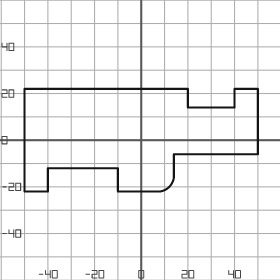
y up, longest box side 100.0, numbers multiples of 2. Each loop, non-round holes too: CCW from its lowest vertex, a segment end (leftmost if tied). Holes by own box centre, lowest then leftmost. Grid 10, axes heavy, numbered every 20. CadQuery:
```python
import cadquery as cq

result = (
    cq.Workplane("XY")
    .moveTo(-50.0, -22.0)
    .lineTo(-40.0, -22.0)
    .lineTo(-40.0, -12.0)
    .lineTo(-10.0, -12.0)
    .lineTo(-10.0, -22.0)
    .lineTo(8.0, -22.0)
    .threePointArc((12.0, -20.0), (14.0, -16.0))
    .lineTo(14.0, -6.0)
    .lineTo(50.0, -6.0)
    .lineTo(50.0, 22.0)
    .lineTo(40.0, 22.0)
    .lineTo(40.0, 14.0)
    .lineTo(20.0, 14.0)
    .lineTo(20.0, 22.0)
    .lineTo(-50.0, 22.0)
    .close()
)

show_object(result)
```